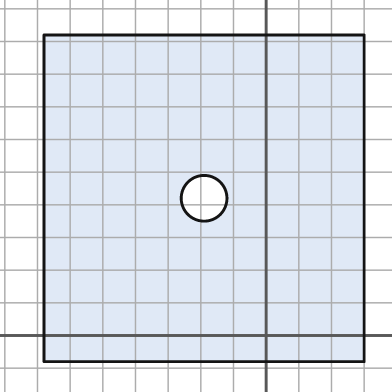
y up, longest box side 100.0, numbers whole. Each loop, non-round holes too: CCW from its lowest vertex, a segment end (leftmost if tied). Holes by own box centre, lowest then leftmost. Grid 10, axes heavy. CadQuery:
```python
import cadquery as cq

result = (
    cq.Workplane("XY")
    .moveTo(-68.0, -8.0)
    .lineTo(30.0, -8.0)
    .lineTo(30.0, 92.0)
    .lineTo(-68.0, 92.0)
    .close()
    .moveTo(-19.0, 42.0)
    .circle(7.0)
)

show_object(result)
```